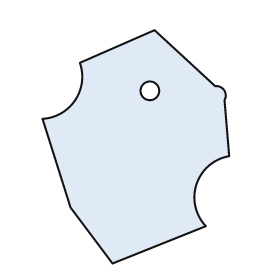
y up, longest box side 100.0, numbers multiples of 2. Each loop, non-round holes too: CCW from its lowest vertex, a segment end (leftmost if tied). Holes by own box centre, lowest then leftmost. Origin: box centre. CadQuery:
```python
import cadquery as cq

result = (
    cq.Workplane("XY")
    .moveTo(-10.0, -50.0)
    .lineTo(30.0, -34.0)
    .threePointArc((26.0, -16.0), (40.0, -4.0))
    .lineTo(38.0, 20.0)
    .threePointArc((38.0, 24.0), (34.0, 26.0))
    .lineTo(8.0, 50.0)
    .lineTo(-24.0, 36.0)
    .threePointArc((-26.0, 20.0), (-40.0, 12.0))
    .lineTo(-28.0, -26.0)
    .close()
    .moveTo(6.0, 24.0)
    .circle(4.0)
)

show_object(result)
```